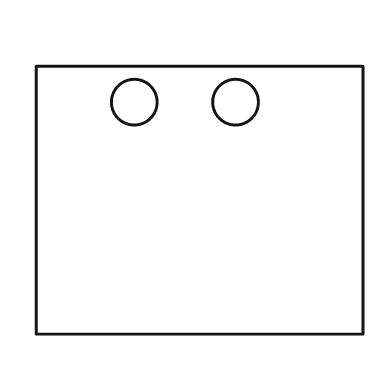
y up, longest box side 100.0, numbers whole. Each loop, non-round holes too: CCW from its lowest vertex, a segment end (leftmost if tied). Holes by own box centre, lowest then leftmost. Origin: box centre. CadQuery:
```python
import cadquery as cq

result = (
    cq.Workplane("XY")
    .moveTo(-50.0, -41.0)
    .lineTo(50.0, -41.0)
    .lineTo(50.0, 41.0)
    .lineTo(-50.0, 41.0)
    .close()
    .moveTo(-20.0, 30.0)
    .circle(7.0)
    .moveTo(11.0, 30.0)
    .circle(7.0)
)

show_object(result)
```